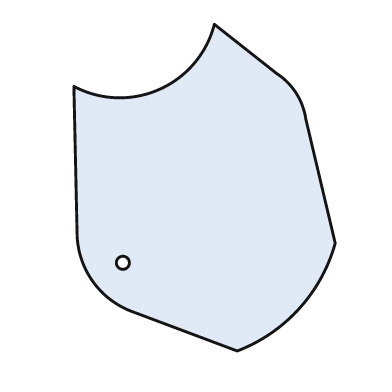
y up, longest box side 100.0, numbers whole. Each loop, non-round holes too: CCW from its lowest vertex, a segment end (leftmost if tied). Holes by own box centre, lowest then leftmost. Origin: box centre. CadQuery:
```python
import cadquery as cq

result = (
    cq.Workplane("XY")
    .moveTo(10.0, -50.0)
    .threePointArc((29.0, -37.0), (40.0, -17.0))
    .lineTo(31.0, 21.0)
    .threePointArc((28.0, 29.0), (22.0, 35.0))
    .lineTo(3.0, 50.0)
    .threePointArc((-14.0, 30.0), (-40.0, 31.0))
    .lineTo(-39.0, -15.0)
    .threePointArc((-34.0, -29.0), (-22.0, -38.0))
    .close()
    .moveTo(-25.0, -23.0)
    .circle(2.0)
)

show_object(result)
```